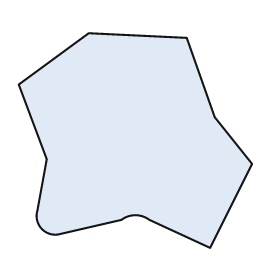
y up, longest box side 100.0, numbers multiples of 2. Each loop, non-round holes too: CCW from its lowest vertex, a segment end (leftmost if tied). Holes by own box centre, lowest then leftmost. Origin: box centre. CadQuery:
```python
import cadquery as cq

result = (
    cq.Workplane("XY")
    .moveTo(32.0, -46.0)
    .lineTo(50.0, -10.0)
    .lineTo(34.0, 10.0)
    .lineTo(22.0, 44.0)
    .lineTo(-20.0, 46.0)
    .lineTo(-50.0, 24.0)
    .lineTo(-38.0, -8.0)
    .lineTo(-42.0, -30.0)
    .threePointArc((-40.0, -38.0), (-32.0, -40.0))
    .lineTo(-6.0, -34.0)
    .threePointArc((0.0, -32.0), (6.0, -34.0))
    .close()
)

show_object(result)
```